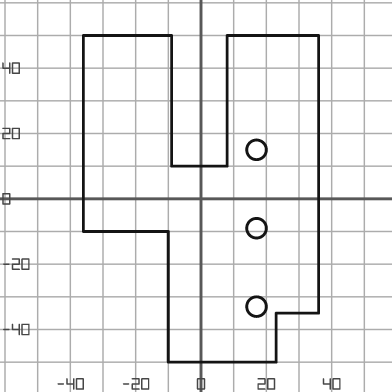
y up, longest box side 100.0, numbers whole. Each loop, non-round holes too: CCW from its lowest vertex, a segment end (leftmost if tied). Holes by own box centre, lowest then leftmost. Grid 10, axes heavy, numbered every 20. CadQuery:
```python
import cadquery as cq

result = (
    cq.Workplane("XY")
    .moveTo(-10.0, -50.0)
    .lineTo(23.0, -50.0)
    .lineTo(23.0, -35.0)
    .lineTo(36.0, -35.0)
    .lineTo(36.0, 50.0)
    .lineTo(8.0, 50.0)
    .lineTo(8.0, 10.0)
    .lineTo(-9.0, 10.0)
    .lineTo(-9.0, 50.0)
    .lineTo(-36.0, 50.0)
    .lineTo(-36.0, -10.0)
    .lineTo(-10.0, -10.0)
    .close()
    .moveTo(17.0, -33.0)
    .circle(3.0)
    .moveTo(17.0, -9.0)
    .circle(3.0)
    .moveTo(17.0, 15.0)
    .circle(3.0)
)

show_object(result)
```